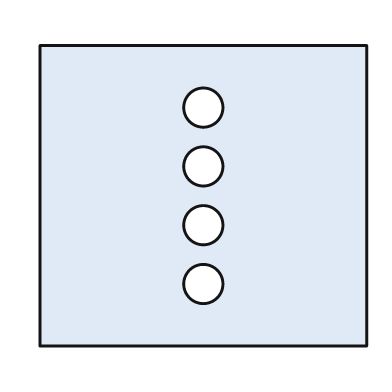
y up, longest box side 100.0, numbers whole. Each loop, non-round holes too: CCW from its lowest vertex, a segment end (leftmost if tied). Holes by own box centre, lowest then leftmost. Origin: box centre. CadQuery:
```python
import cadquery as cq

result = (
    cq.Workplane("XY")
    .moveTo(-50.0, -46.0)
    .lineTo(50.0, -46.0)
    .lineTo(50.0, 46.0)
    .lineTo(-50.0, 46.0)
    .close()
    .moveTo(0.0, -27.0)
    .circle(6.0)
    .moveTo(0.0, -9.0)
    .circle(6.0)
    .moveTo(0.0, 9.0)
    .circle(6.0)
    .moveTo(0.0, 27.0)
    .circle(6.0)
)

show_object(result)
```